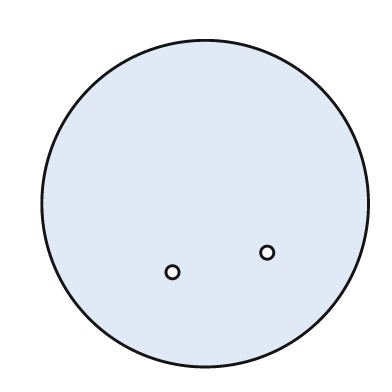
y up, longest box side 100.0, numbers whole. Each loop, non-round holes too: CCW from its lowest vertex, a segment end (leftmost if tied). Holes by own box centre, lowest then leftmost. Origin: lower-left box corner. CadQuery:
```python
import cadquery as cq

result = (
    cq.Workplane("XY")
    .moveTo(50.0, 50.0)
    .circle(50.0)
    .moveTo(40.0, 29.0)
    .circle(2.0)
    .moveTo(69.0, 35.0)
    .circle(2.0)
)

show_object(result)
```